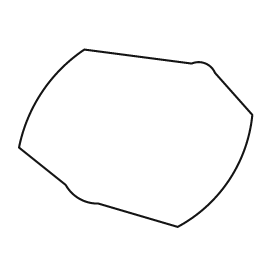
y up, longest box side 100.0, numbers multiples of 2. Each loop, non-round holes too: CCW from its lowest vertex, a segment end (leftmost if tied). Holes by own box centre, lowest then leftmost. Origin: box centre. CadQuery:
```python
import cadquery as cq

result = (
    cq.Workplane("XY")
    .moveTo(18.0, -38.0)
    .threePointArc((40.0, -18.0), (50.0, 10.0))
    .lineTo(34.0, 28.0)
    .threePointArc((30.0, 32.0), (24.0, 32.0))
    .lineTo(-22.0, 38.0)
    .threePointArc((-40.0, 20.0), (-50.0, -4.0))
    .lineTo(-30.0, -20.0)
    .threePointArc((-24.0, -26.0), (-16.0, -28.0))
    .close()
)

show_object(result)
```